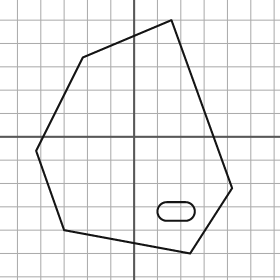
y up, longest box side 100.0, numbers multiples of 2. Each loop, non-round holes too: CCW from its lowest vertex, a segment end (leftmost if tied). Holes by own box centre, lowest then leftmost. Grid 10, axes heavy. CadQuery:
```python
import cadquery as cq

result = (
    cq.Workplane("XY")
    .moveTo(24.0, -50.0)
    .lineTo(42.0, -22.0)
    .lineTo(16.0, 50.0)
    .lineTo(-22.0, 34.0)
    .lineTo(-42.0, -6.0)
    .lineTo(-30.0, -40.0)
    .close()
    .moveTo(14.0, -36.0)
    .lineTo(22.0, -36.0)
    .threePointArc((26.0, -32.0), (22.0, -28.0))
    .lineTo(14.0, -28.0)
    .threePointArc((10.0, -32.0), (14.0, -36.0))
    .close()
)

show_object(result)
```